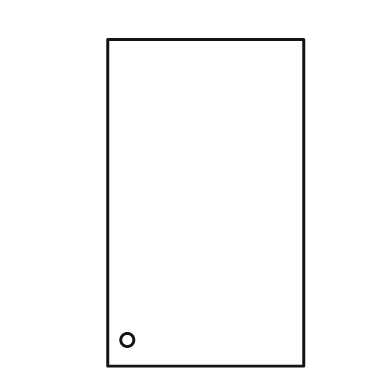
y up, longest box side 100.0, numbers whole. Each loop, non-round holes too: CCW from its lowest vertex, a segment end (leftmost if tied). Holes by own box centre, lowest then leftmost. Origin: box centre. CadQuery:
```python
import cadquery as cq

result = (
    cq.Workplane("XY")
    .moveTo(-30.0, -50.0)
    .lineTo(30.0, -50.0)
    .lineTo(30.0, 50.0)
    .lineTo(-30.0, 50.0)
    .close()
    .moveTo(-24.0, -42.0)
    .circle(2.0)
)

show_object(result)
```